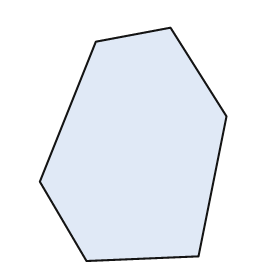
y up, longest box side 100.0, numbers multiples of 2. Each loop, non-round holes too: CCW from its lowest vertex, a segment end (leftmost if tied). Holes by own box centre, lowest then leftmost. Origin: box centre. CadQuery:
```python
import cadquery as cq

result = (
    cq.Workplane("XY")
    .moveTo(-20.0, -50.0)
    .lineTo(28.0, -48.0)
    .lineTo(40.0, 12.0)
    .lineTo(16.0, 50.0)
    .lineTo(-16.0, 44.0)
    .lineTo(-40.0, -16.0)
    .close()
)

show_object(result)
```